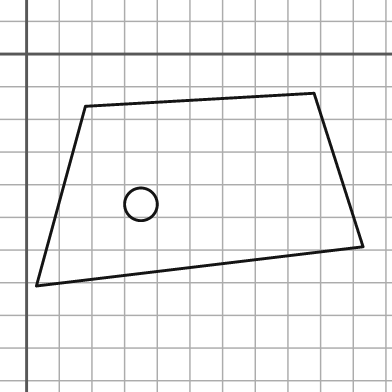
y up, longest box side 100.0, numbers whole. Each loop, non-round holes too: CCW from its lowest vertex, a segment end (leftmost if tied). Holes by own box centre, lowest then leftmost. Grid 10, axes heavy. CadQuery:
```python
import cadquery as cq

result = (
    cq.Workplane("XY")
    .moveTo(3.0, -71.0)
    .lineTo(103.0, -59.0)
    .lineTo(88.0, -12.0)
    .lineTo(18.0, -16.0)
    .close()
    .moveTo(35.0, -46.0)
    .circle(5.0)
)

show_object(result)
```